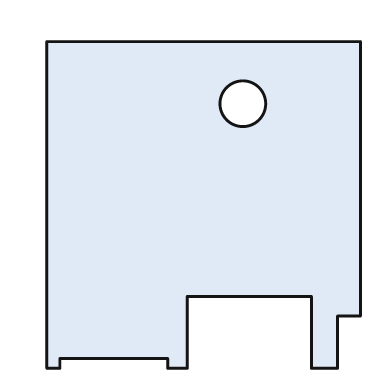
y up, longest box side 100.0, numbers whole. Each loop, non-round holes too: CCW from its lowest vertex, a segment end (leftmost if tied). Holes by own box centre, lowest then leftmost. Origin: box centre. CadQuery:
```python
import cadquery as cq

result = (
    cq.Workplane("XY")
    .moveTo(-48.0, -50.0)
    .lineTo(-44.0, -50.0)
    .lineTo(-44.0, -47.0)
    .lineTo(-11.0, -47.0)
    .lineTo(-11.0, -50.0)
    .lineTo(-5.0, -50.0)
    .lineTo(-5.0, -28.0)
    .lineTo(33.0, -28.0)
    .lineTo(33.0, -50.0)
    .lineTo(41.0, -50.0)
    .lineTo(41.0, -34.0)
    .lineTo(48.0, -34.0)
    .lineTo(48.0, 50.0)
    .lineTo(-48.0, 50.0)
    .close()
    .moveTo(12.0, 31.0)
    .circle(7.0)
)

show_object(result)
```